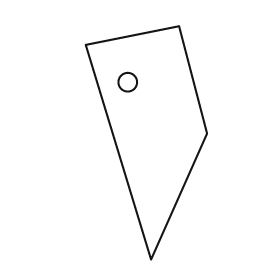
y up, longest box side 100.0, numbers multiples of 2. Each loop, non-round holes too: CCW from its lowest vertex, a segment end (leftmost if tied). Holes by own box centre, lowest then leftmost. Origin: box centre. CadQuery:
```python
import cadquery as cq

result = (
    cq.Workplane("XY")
    .moveTo(2.0, -50.0)
    .lineTo(26.0, 4.0)
    .lineTo(14.0, 50.0)
    .lineTo(-26.0, 42.0)
    .close()
    .moveTo(-8.0, 26.0)
    .circle(4.0)
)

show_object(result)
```